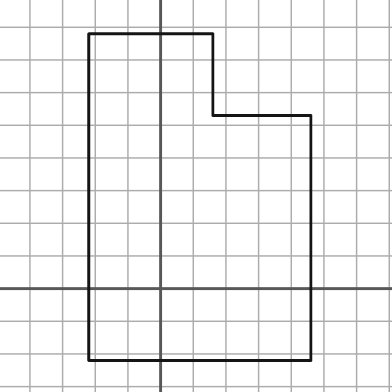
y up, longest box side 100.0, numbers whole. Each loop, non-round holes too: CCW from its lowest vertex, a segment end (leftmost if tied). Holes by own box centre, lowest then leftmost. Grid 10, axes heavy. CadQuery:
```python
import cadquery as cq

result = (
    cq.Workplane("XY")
    .moveTo(-22.0, -22.0)
    .lineTo(46.0, -22.0)
    .lineTo(46.0, 53.0)
    .lineTo(16.0, 53.0)
    .lineTo(16.0, 78.0)
    .lineTo(-22.0, 78.0)
    .close()
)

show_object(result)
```